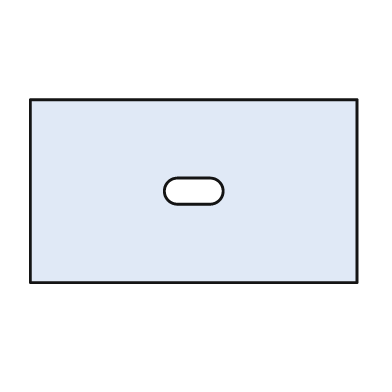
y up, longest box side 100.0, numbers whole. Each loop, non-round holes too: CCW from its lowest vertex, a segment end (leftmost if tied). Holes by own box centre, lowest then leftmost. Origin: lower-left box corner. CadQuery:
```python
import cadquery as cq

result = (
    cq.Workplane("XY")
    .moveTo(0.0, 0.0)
    .lineTo(100.0, 0.0)
    .lineTo(100.0, 56.0)
    .lineTo(0.0, 56.0)
    .close()
    .moveTo(45.0, 24.0)
    .lineTo(55.0, 24.0)
    .threePointArc((59.0, 28.0), (55.0, 32.0))
    .lineTo(45.0, 32.0)
    .threePointArc((41.0, 28.0), (45.0, 24.0))
    .close()
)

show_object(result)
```